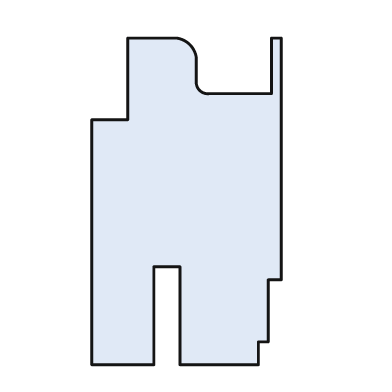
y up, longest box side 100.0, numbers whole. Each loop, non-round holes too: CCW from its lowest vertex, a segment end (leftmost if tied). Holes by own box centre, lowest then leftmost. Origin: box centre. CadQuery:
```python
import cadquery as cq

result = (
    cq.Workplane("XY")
    .moveTo(-29.0, -50.0)
    .lineTo(-10.0, -50.0)
    .lineTo(-10.0, -20.0)
    .lineTo(-2.0, -20.0)
    .lineTo(-2.0, -50.0)
    .lineTo(22.0, -50.0)
    .lineTo(22.0, -43.0)
    .lineTo(25.0, -43.0)
    .lineTo(25.0, -24.0)
    .lineTo(29.0, -24.0)
    .lineTo(29.0, 50.0)
    .lineTo(26.0, 50.0)
    .lineTo(26.0, 33.0)
    .lineTo(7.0, 33.0)
    .threePointArc((4.0, 34.0), (3.0, 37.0))
    .lineTo(3.0, 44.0)
    .threePointArc((1.0, 48.0), (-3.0, 50.0))
    .lineTo(-18.0, 50.0)
    .lineTo(-18.0, 25.0)
    .lineTo(-29.0, 25.0)
    .close()
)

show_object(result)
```